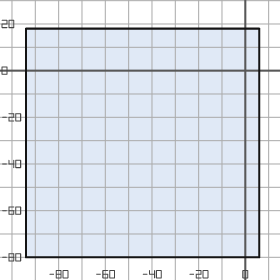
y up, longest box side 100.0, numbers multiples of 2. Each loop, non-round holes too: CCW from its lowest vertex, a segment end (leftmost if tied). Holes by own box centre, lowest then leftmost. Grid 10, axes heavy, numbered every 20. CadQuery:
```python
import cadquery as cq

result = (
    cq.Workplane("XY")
    .moveTo(-94.0, -80.0)
    .lineTo(6.0, -80.0)
    .lineTo(6.0, 18.0)
    .lineTo(-94.0, 18.0)
    .close()
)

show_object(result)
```